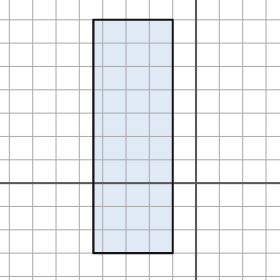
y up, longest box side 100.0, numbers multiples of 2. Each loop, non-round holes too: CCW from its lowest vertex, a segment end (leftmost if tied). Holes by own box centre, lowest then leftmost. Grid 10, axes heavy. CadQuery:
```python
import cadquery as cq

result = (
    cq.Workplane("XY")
    .moveTo(-44.0, -30.0)
    .lineTo(-10.0, -30.0)
    .lineTo(-10.0, 70.0)
    .lineTo(-44.0, 70.0)
    .close()
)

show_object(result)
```